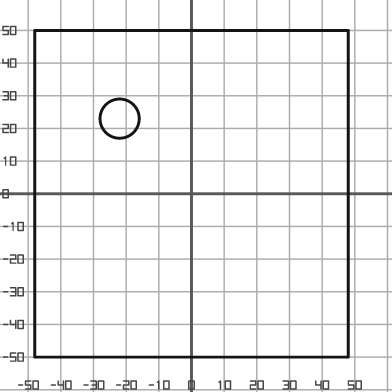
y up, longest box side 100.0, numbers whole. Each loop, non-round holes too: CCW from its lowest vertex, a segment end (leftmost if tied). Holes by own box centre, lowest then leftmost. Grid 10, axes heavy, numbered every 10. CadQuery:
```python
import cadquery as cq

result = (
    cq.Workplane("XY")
    .moveTo(-48.0, -50.0)
    .lineTo(48.0, -50.0)
    .lineTo(48.0, 50.0)
    .lineTo(-48.0, 50.0)
    .close()
    .moveTo(-22.0, 23.0)
    .circle(6.0)
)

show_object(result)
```